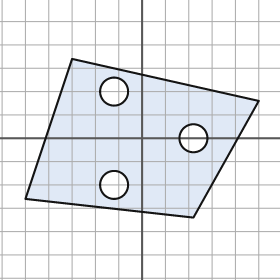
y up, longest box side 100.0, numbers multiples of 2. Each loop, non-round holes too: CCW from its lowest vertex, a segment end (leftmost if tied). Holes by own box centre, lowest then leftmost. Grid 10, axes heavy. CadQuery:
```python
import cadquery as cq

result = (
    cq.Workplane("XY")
    .moveTo(22.0, -34.0)
    .lineTo(50.0, 16.0)
    .lineTo(-30.0, 34.0)
    .lineTo(-50.0, -26.0)
    .close()
    .moveTo(-12.0, -20.0)
    .circle(6.0)
    .moveTo(22.0, 0.0)
    .circle(6.0)
    .moveTo(-12.0, 20.0)
    .circle(6.0)
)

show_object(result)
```